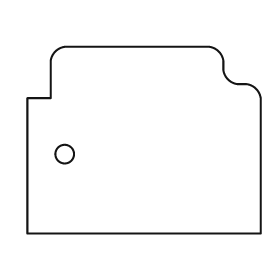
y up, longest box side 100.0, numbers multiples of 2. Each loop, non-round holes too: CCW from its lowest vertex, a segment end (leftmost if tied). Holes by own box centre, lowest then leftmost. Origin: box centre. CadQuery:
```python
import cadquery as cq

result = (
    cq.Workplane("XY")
    .moveTo(-50.0, -40.0)
    .lineTo(50.0, -40.0)
    .lineTo(50.0, 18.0)
    .threePointArc((48.0, 22.0), (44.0, 24.0))
    .lineTo(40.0, 24.0)
    .threePointArc((36.0, 26.0), (34.0, 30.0))
    .lineTo(34.0, 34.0)
    .threePointArc((32.0, 38.0), (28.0, 40.0))
    .lineTo(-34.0, 40.0)
    .threePointArc((-38.0, 38.0), (-40.0, 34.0))
    .lineTo(-40.0, 18.0)
    .lineTo(-50.0, 18.0)
    .close()
    .moveTo(-34.0, -6.0)
    .circle(4.0)
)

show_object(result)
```